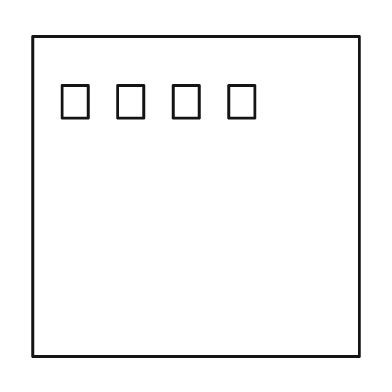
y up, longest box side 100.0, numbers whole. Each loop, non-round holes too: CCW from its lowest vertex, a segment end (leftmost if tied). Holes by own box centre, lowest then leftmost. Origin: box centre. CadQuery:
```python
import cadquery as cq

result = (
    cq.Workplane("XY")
    .moveTo(-50.0, -49.0)
    .lineTo(50.0, -49.0)
    .lineTo(50.0, 49.0)
    .lineTo(-50.0, 49.0)
    .close()
    .moveTo(-41.0, 24.0)
    .lineTo(-33.0, 24.0)
    .lineTo(-33.0, 34.0)
    .lineTo(-41.0, 34.0)
    .close()
    .moveTo(-24.0, 24.0)
    .lineTo(-16.0, 24.0)
    .lineTo(-16.0, 34.0)
    .lineTo(-24.0, 34.0)
    .close()
    .moveTo(-7.0, 24.0)
    .lineTo(1.0, 24.0)
    .lineTo(1.0, 34.0)
    .lineTo(-7.0, 34.0)
    .close()
    .moveTo(10.0, 24.0)
    .lineTo(18.0, 24.0)
    .lineTo(18.0, 34.0)
    .lineTo(10.0, 34.0)
    .close()
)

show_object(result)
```